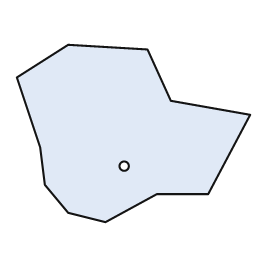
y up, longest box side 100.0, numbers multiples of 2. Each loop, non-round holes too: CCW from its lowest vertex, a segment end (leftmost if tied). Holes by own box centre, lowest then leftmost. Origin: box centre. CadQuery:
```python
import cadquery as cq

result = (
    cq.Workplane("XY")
    .moveTo(-12.0, -38.0)
    .lineTo(10.0, -26.0)
    .lineTo(32.0, -26.0)
    .lineTo(50.0, 8.0)
    .lineTo(16.0, 14.0)
    .lineTo(6.0, 36.0)
    .lineTo(-28.0, 38.0)
    .lineTo(-50.0, 24.0)
    .lineTo(-40.0, -6.0)
    .lineTo(-38.0, -22.0)
    .lineTo(-28.0, -34.0)
    .close()
    .moveTo(-4.0, -14.0)
    .circle(2.0)
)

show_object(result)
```